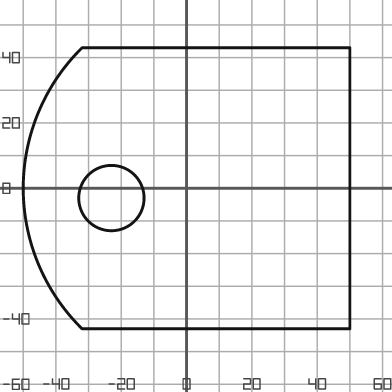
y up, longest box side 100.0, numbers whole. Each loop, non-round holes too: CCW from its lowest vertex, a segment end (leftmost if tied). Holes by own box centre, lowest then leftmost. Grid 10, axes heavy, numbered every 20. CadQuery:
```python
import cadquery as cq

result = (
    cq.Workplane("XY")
    .moveTo(-32.0, -43.0)
    .lineTo(50.0, -43.0)
    .lineTo(50.0, 43.0)
    .lineTo(-32.0, 43.0)
    .threePointArc((-50.0, 0.0), (-32.0, -43.0))
    .close()
    .moveTo(-23.0, -3.0)
    .circle(10.0)
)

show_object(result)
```